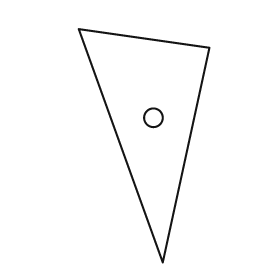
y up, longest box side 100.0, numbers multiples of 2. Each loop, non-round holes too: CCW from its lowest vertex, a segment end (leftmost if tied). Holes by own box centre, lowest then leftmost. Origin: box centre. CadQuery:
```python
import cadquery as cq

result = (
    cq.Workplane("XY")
    .moveTo(8.0, -50.0)
    .lineTo(28.0, 42.0)
    .lineTo(-28.0, 50.0)
    .close()
    .moveTo(4.0, 12.0)
    .circle(4.0)
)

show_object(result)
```